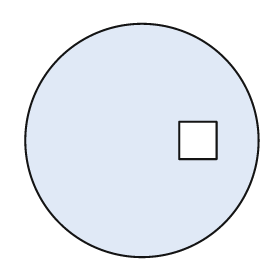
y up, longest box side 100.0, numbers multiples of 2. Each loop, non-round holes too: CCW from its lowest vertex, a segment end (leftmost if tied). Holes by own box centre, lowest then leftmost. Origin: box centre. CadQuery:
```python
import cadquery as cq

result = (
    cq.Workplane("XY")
    .moveTo(0.0, 0.0)
    .circle(50.0)
    .moveTo(16.0, -8.0)
    .lineTo(32.0, -8.0)
    .lineTo(32.0, 8.0)
    .lineTo(16.0, 8.0)
    .close()
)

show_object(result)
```